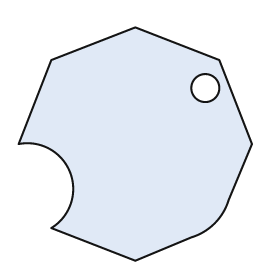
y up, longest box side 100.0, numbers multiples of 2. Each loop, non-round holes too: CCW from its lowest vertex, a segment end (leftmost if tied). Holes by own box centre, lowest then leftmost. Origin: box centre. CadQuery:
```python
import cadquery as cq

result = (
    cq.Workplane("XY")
    .moveTo(0.0, -50.0)
    .lineTo(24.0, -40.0)
    .threePointArc((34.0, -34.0), (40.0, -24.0))
    .lineTo(50.0, 0.0)
    .lineTo(36.0, 36.0)
    .lineTo(0.0, 50.0)
    .lineTo(-36.0, 36.0)
    .lineTo(-50.0, 0.0)
    .threePointArc((-28.0, -12.0), (-36.0, -36.0))
    .close()
    .moveTo(30.0, 24.0)
    .circle(6.0)
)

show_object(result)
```